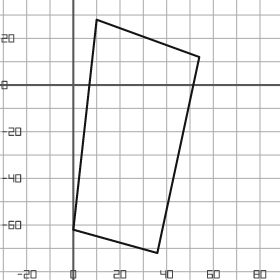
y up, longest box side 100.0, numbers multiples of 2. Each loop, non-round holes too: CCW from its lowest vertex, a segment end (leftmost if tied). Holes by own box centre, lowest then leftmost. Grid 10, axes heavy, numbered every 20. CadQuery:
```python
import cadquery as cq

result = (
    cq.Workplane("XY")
    .moveTo(36.0, -72.0)
    .lineTo(54.0, 12.0)
    .lineTo(10.0, 28.0)
    .lineTo(0.0, -62.0)
    .close()
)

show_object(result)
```